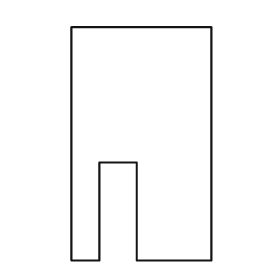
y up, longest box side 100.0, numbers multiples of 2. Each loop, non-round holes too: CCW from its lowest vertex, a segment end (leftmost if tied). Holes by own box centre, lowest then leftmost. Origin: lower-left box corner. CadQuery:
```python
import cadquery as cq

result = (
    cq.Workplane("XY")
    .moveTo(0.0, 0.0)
    .lineTo(12.0, 0.0)
    .lineTo(12.0, 42.0)
    .lineTo(28.0, 42.0)
    .lineTo(28.0, 0.0)
    .lineTo(60.0, 0.0)
    .lineTo(60.0, 100.0)
    .lineTo(0.0, 100.0)
    .close()
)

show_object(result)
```